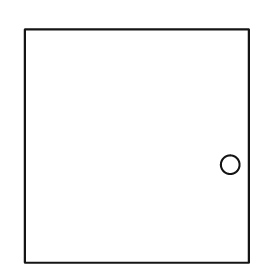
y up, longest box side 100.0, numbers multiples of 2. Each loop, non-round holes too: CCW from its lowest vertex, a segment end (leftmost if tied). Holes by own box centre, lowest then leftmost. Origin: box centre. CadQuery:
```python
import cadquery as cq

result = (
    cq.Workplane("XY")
    .moveTo(-48.0, -50.0)
    .lineTo(48.0, -50.0)
    .lineTo(48.0, 50.0)
    .lineTo(-48.0, 50.0)
    .close()
    .moveTo(40.0, -8.0)
    .circle(4.0)
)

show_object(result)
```